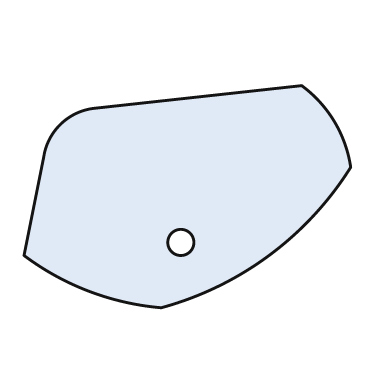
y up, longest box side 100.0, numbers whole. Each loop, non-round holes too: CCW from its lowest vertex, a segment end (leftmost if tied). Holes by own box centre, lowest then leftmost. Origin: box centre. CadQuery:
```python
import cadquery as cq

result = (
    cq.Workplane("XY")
    .moveTo(-8.0, -34.0)
    .threePointArc((25.0, -18.0), (50.0, 9.0))
    .threePointArc((45.0, 23.0), (35.0, 34.0))
    .lineTo(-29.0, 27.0)
    .threePointArc((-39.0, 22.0), (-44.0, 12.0))
    .lineTo(-50.0, -18.0)
    .threePointArc((-30.0, -29.0), (-8.0, -34.0))
    .close()
    .moveTo(-2.0, -14.0)
    .circle(4.0)
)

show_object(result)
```